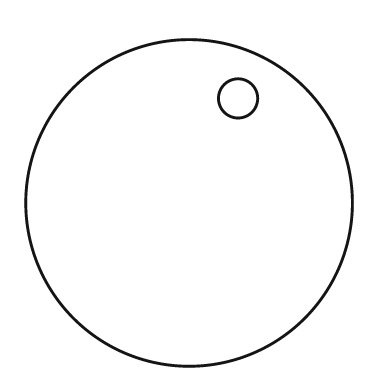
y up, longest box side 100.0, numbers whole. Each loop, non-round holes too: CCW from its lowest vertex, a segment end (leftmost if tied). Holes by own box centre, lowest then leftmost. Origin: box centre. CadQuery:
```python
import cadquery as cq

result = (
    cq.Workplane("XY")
    .moveTo(0.0, 0.0)
    .circle(50.0)
    .moveTo(15.0, 32.0)
    .circle(6.0)
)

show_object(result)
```